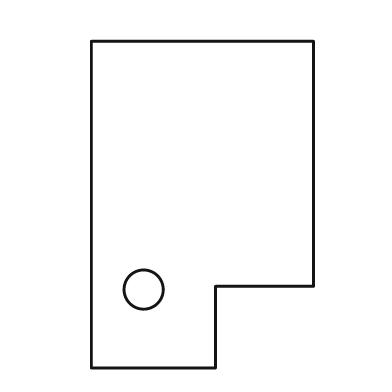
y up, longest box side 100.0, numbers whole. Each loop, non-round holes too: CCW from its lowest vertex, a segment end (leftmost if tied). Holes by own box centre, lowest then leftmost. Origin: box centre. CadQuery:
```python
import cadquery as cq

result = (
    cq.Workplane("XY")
    .moveTo(-34.0, -50.0)
    .lineTo(4.0, -50.0)
    .lineTo(4.0, -25.0)
    .lineTo(34.0, -25.0)
    .lineTo(34.0, 50.0)
    .lineTo(-34.0, 50.0)
    .close()
    .moveTo(-18.0, -26.0)
    .circle(6.0)
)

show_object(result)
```